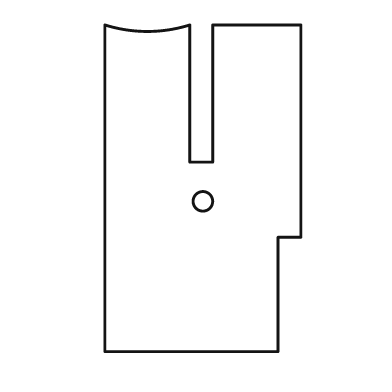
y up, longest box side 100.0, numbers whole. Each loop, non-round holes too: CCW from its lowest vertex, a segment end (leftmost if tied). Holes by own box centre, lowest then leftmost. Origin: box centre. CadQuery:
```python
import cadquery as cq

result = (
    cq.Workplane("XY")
    .moveTo(-30.0, -50.0)
    .lineTo(23.0, -50.0)
    .lineTo(23.0, -15.0)
    .lineTo(30.0, -15.0)
    .lineTo(30.0, 50.0)
    .lineTo(3.0, 50.0)
    .lineTo(3.0, 8.0)
    .lineTo(-4.0, 8.0)
    .lineTo(-4.0, 50.0)
    .threePointArc((-17.0, 48.0), (-30.0, 50.0))
    .close()
    .moveTo(0.0, -4.0)
    .circle(3.0)
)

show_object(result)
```